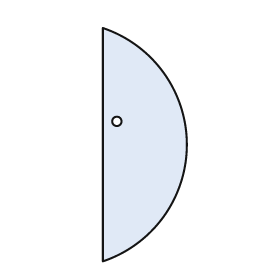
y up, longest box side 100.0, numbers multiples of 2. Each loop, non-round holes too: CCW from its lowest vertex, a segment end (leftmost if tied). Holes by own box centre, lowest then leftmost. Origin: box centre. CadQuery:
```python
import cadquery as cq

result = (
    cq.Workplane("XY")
    .moveTo(-18.0, -50.0)
    .threePointArc((18.0, 0.0), (-18.0, 50.0))
    .close()
    .moveTo(-12.0, 10.0)
    .circle(2.0)
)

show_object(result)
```